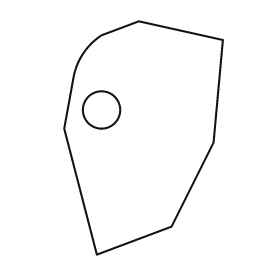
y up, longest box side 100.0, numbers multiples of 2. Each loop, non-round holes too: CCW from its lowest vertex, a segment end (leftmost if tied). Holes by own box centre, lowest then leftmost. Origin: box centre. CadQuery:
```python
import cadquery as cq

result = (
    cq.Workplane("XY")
    .moveTo(-20.0, -50.0)
    .lineTo(12.0, -38.0)
    .lineTo(30.0, -2.0)
    .lineTo(34.0, 42.0)
    .lineTo(-2.0, 50.0)
    .lineTo(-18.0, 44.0)
    .threePointArc((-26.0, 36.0), (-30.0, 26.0))
    .lineTo(-34.0, 4.0)
    .close()
    .moveTo(-18.0, 12.0)
    .circle(8.0)
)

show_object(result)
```